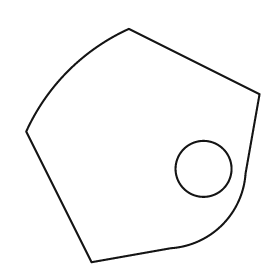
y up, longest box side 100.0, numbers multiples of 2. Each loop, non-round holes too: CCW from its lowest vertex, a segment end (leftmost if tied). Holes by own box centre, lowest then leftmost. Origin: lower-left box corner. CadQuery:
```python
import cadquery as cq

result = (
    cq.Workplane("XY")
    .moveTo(28.0, 0.0)
    .lineTo(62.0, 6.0)
    .threePointArc((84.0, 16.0), (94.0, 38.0))
    .lineTo(100.0, 72.0)
    .lineTo(44.0, 100.0)
    .threePointArc((18.0, 82.0), (0.0, 56.0))
    .close()
    .moveTo(76.0, 40.0)
    .circle(12.0)
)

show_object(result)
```